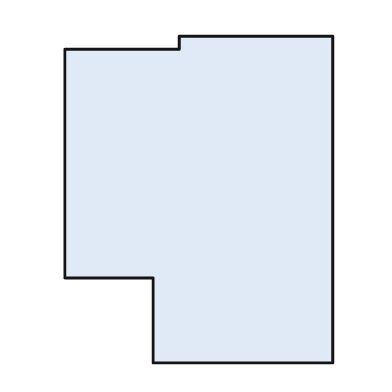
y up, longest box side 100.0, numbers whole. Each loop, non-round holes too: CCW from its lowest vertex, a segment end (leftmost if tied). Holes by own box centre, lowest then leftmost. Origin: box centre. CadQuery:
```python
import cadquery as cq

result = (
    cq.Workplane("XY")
    .moveTo(-14.0, -50.0)
    .lineTo(41.0, -50.0)
    .lineTo(41.0, 50.0)
    .lineTo(-6.0, 50.0)
    .lineTo(-6.0, 46.0)
    .lineTo(-41.0, 46.0)
    .lineTo(-41.0, -24.0)
    .lineTo(-14.0, -24.0)
    .close()
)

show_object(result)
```